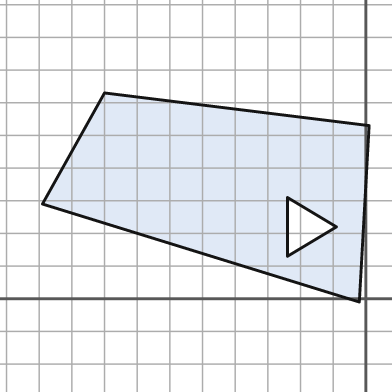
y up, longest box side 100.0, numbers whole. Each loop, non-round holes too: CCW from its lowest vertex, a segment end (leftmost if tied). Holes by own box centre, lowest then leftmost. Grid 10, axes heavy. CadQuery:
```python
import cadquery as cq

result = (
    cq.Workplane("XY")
    .moveTo(-2.0, -1.0)
    .lineTo(1.0, 53.0)
    .lineTo(-80.0, 63.0)
    .lineTo(-99.0, 29.0)
    .close()
    .moveTo(-24.0, 13.0)
    .lineTo(-9.0, 22.0)
    .lineTo(-24.0, 31.0)
    .close()
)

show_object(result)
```